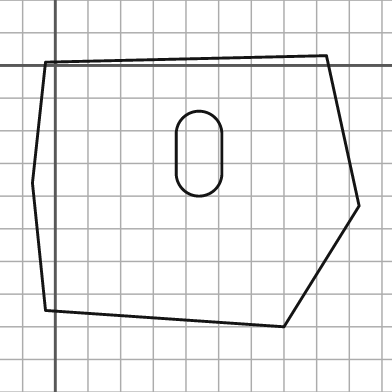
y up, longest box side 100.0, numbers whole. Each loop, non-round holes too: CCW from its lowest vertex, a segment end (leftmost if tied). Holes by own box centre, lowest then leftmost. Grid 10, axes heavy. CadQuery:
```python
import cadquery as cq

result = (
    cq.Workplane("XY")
    .moveTo(70.0, -80.0)
    .lineTo(93.0, -43.0)
    .lineTo(83.0, 3.0)
    .lineTo(-3.0, 1.0)
    .lineTo(-7.0, -36.0)
    .lineTo(-3.0, -75.0)
    .close()
    .moveTo(37.0, -33.0)
    .threePointArc((44.0, -40.0), (51.0, -33.0))
    .lineTo(51.0, -21.0)
    .threePointArc((44.0, -14.0), (37.0, -21.0))
    .close()
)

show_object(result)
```